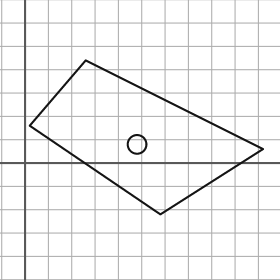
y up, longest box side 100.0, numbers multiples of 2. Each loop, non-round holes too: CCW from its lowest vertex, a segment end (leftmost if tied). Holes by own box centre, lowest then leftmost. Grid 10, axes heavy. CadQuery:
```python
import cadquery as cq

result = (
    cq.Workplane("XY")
    .moveTo(58.0, -22.0)
    .lineTo(102.0, 6.0)
    .lineTo(26.0, 44.0)
    .lineTo(2.0, 16.0)
    .close()
    .moveTo(48.0, 8.0)
    .circle(4.0)
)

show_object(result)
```